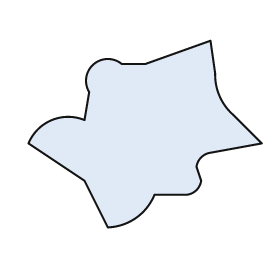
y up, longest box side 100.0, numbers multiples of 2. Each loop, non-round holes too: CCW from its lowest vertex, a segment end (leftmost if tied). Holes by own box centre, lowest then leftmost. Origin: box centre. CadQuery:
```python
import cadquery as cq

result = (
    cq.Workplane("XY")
    .moveTo(-16.0, -40.0)
    .threePointArc((-4.0, -36.0), (4.0, -26.0))
    .lineTo(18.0, -26.0)
    .threePointArc((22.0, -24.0), (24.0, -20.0))
    .lineTo(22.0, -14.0)
    .threePointArc((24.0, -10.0), (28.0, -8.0))
    .lineTo(50.0, -4.0)
    .lineTo(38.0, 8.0)
    .threePointArc((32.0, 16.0), (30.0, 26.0))
    .lineTo(28.0, 40.0)
    .lineTo(0.0, 30.0)
    .lineTo(-10.0, 30.0)
    .threePointArc((-22.0, 30.0), (-24.0, 18.0))
    .lineTo(-26.0, 6.0)
    .threePointArc((-40.0, 6.0), (-50.0, -4.0))
    .lineTo(-26.0, -20.0)
    .close()
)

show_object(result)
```